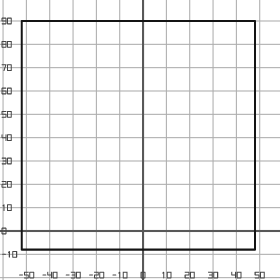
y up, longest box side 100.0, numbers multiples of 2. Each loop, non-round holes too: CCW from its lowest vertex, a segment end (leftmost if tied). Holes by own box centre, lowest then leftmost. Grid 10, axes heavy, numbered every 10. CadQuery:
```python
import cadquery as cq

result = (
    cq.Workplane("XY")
    .moveTo(-52.0, -8.0)
    .lineTo(48.0, -8.0)
    .lineTo(48.0, 90.0)
    .lineTo(-52.0, 90.0)
    .close()
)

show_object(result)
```